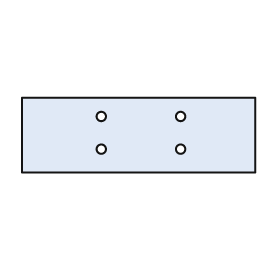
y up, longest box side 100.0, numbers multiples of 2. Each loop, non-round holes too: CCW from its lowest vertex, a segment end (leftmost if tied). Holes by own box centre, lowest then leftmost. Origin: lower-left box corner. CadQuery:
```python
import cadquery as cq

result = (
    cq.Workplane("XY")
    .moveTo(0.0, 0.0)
    .lineTo(100.0, 0.0)
    .lineTo(100.0, 32.0)
    .lineTo(0.0, 32.0)
    .close()
    .moveTo(34.0, 10.0)
    .circle(2.0)
    .moveTo(68.0, 10.0)
    .circle(2.0)
    .moveTo(34.0, 24.0)
    .circle(2.0)
    .moveTo(68.0, 24.0)
    .circle(2.0)
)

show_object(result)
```